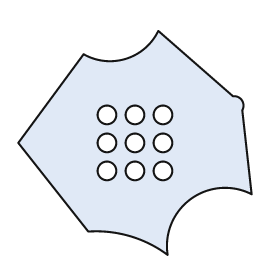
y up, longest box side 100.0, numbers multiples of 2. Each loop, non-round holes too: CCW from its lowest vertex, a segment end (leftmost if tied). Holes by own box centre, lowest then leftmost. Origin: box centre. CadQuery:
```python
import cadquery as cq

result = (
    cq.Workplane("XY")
    .moveTo(14.0, -48.0)
    .threePointArc((24.0, -24.0), (50.0, -22.0))
    .lineTo(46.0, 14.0)
    .threePointArc((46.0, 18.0), (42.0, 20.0))
    .lineTo(10.0, 48.0)
    .threePointArc((-4.0, 36.0), (-22.0, 38.0))
    .lineTo(-50.0, 0.0)
    .lineTo(-20.0, -38.0)
    .threePointArc((-2.0, -40.0), (14.0, -48.0))
    .close()
    .moveTo(-12.0, -12.0)
    .circle(4.0)
    .moveTo(0.0, -12.0)
    .circle(4.0)
    .moveTo(12.0, -12.0)
    .circle(4.0)
    .moveTo(-12.0, 0.0)
    .circle(4.0)
    .moveTo(0.0, 0.0)
    .circle(4.0)
    .moveTo(12.0, 0.0)
    .circle(4.0)
    .moveTo(-12.0, 12.0)
    .circle(4.0)
    .moveTo(0.0, 12.0)
    .circle(4.0)
    .moveTo(12.0, 12.0)
    .circle(4.0)
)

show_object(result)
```